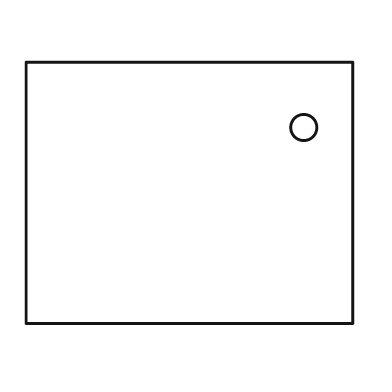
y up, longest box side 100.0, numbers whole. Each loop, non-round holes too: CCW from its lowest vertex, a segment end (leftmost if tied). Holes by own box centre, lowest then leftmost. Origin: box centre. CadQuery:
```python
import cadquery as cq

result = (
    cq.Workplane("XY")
    .moveTo(-50.0, -40.0)
    .lineTo(50.0, -40.0)
    .lineTo(50.0, 40.0)
    .lineTo(-50.0, 40.0)
    .close()
    .moveTo(35.0, 20.0)
    .circle(4.0)
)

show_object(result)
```